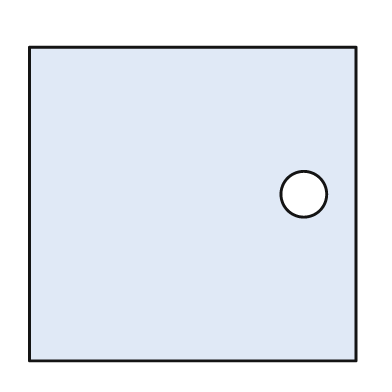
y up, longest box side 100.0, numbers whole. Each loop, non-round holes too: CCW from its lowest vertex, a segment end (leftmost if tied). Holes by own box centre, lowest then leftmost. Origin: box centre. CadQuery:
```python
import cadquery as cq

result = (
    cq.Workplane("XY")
    .moveTo(-50.0, -48.0)
    .lineTo(50.0, -48.0)
    .lineTo(50.0, 48.0)
    .lineTo(-50.0, 48.0)
    .close()
    .moveTo(34.0, 3.0)
    .circle(7.0)
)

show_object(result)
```